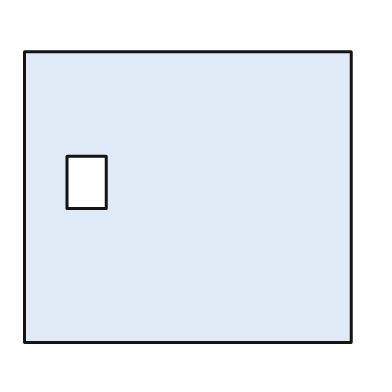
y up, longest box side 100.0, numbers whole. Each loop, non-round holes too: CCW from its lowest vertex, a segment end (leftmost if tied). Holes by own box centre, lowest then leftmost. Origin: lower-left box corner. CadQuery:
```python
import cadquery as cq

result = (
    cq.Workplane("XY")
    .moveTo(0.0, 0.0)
    .lineTo(100.0, 0.0)
    .lineTo(100.0, 89.0)
    .lineTo(0.0, 89.0)
    .close()
    .moveTo(13.0, 41.0)
    .lineTo(25.0, 41.0)
    .lineTo(25.0, 57.0)
    .lineTo(13.0, 57.0)
    .close()
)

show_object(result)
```